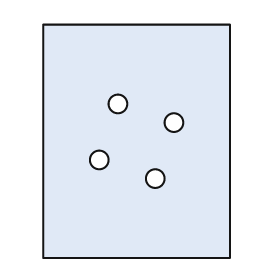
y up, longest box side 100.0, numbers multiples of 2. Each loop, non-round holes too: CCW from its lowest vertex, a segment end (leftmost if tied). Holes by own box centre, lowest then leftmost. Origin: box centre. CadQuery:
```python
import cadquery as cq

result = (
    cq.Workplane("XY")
    .moveTo(-40.0, -50.0)
    .lineTo(40.0, -50.0)
    .lineTo(40.0, 50.0)
    .lineTo(-40.0, 50.0)
    .close()
    .moveTo(8.0, -16.0)
    .circle(4.0)
    .moveTo(-16.0, -8.0)
    .circle(4.0)
    .moveTo(16.0, 8.0)
    .circle(4.0)
    .moveTo(-8.0, 16.0)
    .circle(4.0)
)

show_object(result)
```